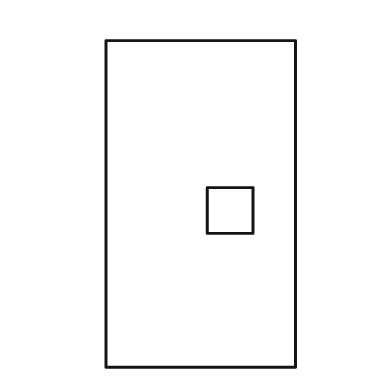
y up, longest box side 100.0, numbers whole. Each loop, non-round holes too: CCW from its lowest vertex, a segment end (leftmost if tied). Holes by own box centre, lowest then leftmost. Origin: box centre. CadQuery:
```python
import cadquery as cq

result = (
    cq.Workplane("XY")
    .moveTo(-29.0, -50.0)
    .lineTo(29.0, -50.0)
    .lineTo(29.0, 50.0)
    .lineTo(-29.0, 50.0)
    .close()
    .moveTo(2.0, -9.0)
    .lineTo(16.0, -9.0)
    .lineTo(16.0, 5.0)
    .lineTo(2.0, 5.0)
    .close()
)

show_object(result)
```